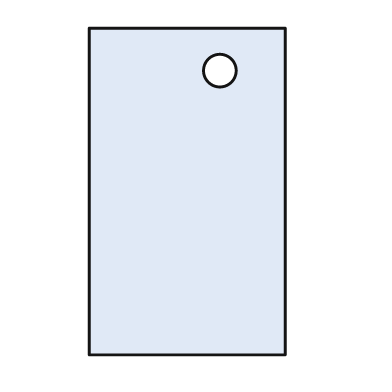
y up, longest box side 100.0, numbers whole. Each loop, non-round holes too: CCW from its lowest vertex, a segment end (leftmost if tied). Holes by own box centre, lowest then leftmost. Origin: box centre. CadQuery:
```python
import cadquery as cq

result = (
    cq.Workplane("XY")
    .moveTo(-30.0, -50.0)
    .lineTo(30.0, -50.0)
    .lineTo(30.0, 50.0)
    .lineTo(-30.0, 50.0)
    .close()
    .moveTo(10.0, 37.0)
    .circle(5.0)
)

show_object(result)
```